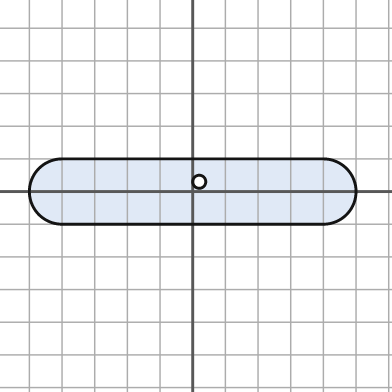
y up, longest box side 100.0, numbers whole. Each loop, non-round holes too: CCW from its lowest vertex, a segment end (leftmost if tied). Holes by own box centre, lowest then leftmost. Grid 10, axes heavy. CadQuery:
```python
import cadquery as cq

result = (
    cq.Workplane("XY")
    .moveTo(-40.0, -10.0)
    .lineTo(40.0, -10.0)
    .threePointArc((50.0, 0.0), (40.0, 10.0))
    .lineTo(-40.0, 10.0)
    .threePointArc((-50.0, 0.0), (-40.0, -10.0))
    .close()
    .moveTo(2.0, 3.0)
    .circle(2.0)
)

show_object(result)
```